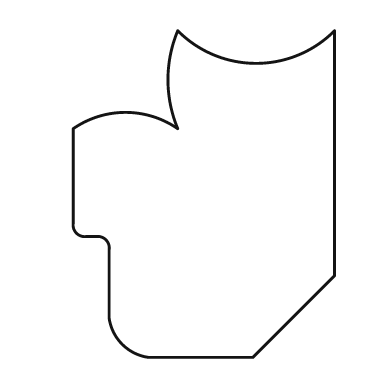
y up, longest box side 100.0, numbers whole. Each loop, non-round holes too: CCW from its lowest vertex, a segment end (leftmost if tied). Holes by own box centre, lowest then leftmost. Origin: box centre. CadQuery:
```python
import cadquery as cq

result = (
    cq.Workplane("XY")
    .moveTo(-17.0, -50.0)
    .lineTo(15.0, -50.0)
    .lineTo(40.0, -25.0)
    .lineTo(40.0, 50.0)
    .threePointArc((16.0, 40.0), (-8.0, 50.0))
    .threePointArc((-11.0, 35.0), (-8.0, 20.0))
    .threePointArc((-24.0, 25.0), (-40.0, 20.0))
    .lineTo(-40.0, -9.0)
    .threePointArc((-39.0, -12.0), (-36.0, -13.0))
    .lineTo(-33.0, -13.0)
    .threePointArc((-30.0, -14.0), (-29.0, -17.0))
    .lineTo(-29.0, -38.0)
    .threePointArc((-25.0, -46.0), (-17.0, -50.0))
    .close()
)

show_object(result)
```